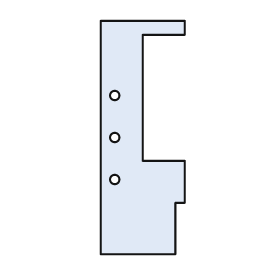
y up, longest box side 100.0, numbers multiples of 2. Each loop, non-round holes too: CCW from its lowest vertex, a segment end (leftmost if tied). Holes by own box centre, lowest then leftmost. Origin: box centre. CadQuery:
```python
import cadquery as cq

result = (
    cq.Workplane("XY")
    .moveTo(-18.0, -50.0)
    .lineTo(14.0, -50.0)
    .lineTo(14.0, -28.0)
    .lineTo(18.0, -28.0)
    .lineTo(18.0, -10.0)
    .lineTo(0.0, -10.0)
    .lineTo(0.0, 44.0)
    .lineTo(18.0, 44.0)
    .lineTo(18.0, 50.0)
    .lineTo(-18.0, 50.0)
    .close()
    .moveTo(-12.0, -18.0)
    .circle(2.0)
    .moveTo(-12.0, 0.0)
    .circle(2.0)
    .moveTo(-12.0, 18.0)
    .circle(2.0)
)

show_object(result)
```